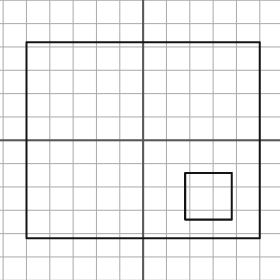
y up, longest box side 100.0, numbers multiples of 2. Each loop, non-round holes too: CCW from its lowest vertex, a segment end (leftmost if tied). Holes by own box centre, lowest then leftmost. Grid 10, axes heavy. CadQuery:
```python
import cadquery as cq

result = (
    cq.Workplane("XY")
    .moveTo(-50.0, -42.0)
    .lineTo(50.0, -42.0)
    .lineTo(50.0, 42.0)
    .lineTo(-50.0, 42.0)
    .close()
    .moveTo(18.0, -34.0)
    .lineTo(38.0, -34.0)
    .lineTo(38.0, -14.0)
    .lineTo(18.0, -14.0)
    .close()
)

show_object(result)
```